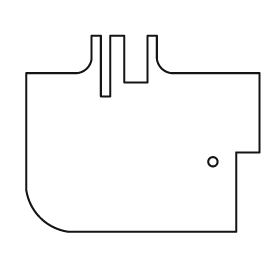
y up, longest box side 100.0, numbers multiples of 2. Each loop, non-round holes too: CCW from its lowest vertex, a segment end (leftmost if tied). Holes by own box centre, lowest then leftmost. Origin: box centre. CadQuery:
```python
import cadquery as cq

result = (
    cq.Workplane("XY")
    .moveTo(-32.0, -42.0)
    .lineTo(40.0, -42.0)
    .lineTo(40.0, -8.0)
    .lineTo(50.0, -8.0)
    .lineTo(50.0, 26.0)
    .lineTo(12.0, 26.0)
    .threePointArc((8.0, 28.0), (6.0, 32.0))
    .lineTo(6.0, 42.0)
    .lineTo(2.0, 42.0)
    .lineTo(2.0, 22.0)
    .lineTo(-8.0, 22.0)
    .lineTo(-8.0, 42.0)
    .lineTo(-14.0, 42.0)
    .lineTo(-14.0, 16.0)
    .lineTo(-18.0, 16.0)
    .lineTo(-18.0, 42.0)
    .lineTo(-22.0, 42.0)
    .lineTo(-22.0, 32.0)
    .threePointArc((-24.0, 28.0), (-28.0, 26.0))
    .lineTo(-50.0, 26.0)
    .lineTo(-50.0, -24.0)
    .threePointArc((-44.0, -36.0), (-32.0, -42.0))
    .close()
    .moveTo(30.0, -12.0)
    .circle(2.0)
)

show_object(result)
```